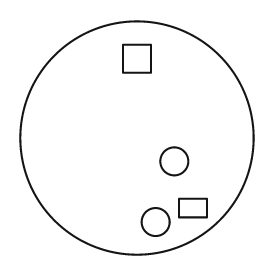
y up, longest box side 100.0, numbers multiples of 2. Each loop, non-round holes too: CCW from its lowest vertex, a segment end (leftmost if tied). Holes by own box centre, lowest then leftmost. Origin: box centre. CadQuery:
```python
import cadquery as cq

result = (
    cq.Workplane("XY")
    .moveTo(0.0, 0.0)
    .circle(50.0)
    .moveTo(8.0, -36.0)
    .circle(6.0)
    .moveTo(18.0, -34.0)
    .lineTo(30.0, -34.0)
    .lineTo(30.0, -26.0)
    .lineTo(18.0, -26.0)
    .close()
    .moveTo(16.0, -10.0)
    .circle(6.0)
    .moveTo(-6.0, 28.0)
    .lineTo(6.0, 28.0)
    .lineTo(6.0, 40.0)
    .lineTo(-6.0, 40.0)
    .close()
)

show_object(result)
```